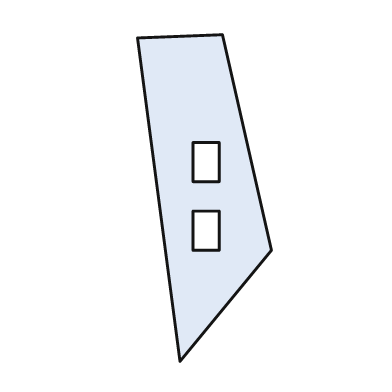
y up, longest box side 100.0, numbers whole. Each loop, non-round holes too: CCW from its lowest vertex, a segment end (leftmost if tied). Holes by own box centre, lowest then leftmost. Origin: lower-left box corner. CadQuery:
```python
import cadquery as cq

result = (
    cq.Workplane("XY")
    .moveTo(13.0, 0.0)
    .lineTo(41.0, 34.0)
    .lineTo(26.0, 100.0)
    .lineTo(0.0, 99.0)
    .close()
    .moveTo(17.0, 34.0)
    .lineTo(25.0, 34.0)
    .lineTo(25.0, 46.0)
    .lineTo(17.0, 46.0)
    .close()
    .moveTo(17.0, 55.0)
    .lineTo(25.0, 55.0)
    .lineTo(25.0, 67.0)
    .lineTo(17.0, 67.0)
    .close()
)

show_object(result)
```